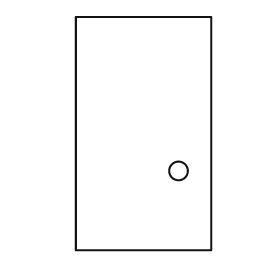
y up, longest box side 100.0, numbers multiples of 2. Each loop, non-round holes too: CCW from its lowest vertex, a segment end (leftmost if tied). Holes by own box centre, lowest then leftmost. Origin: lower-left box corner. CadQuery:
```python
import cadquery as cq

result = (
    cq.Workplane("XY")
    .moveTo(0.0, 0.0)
    .lineTo(58.0, 0.0)
    .lineTo(58.0, 100.0)
    .lineTo(0.0, 100.0)
    .close()
    .moveTo(44.0, 34.0)
    .circle(4.0)
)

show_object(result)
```